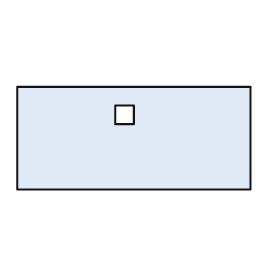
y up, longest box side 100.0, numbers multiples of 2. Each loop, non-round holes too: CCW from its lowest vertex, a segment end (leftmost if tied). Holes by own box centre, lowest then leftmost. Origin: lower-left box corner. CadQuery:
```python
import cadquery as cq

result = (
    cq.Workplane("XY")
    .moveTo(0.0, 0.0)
    .lineTo(100.0, 0.0)
    .lineTo(100.0, 44.0)
    .lineTo(0.0, 44.0)
    .close()
    .moveTo(42.0, 28.0)
    .lineTo(50.0, 28.0)
    .lineTo(50.0, 36.0)
    .lineTo(42.0, 36.0)
    .close()
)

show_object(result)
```